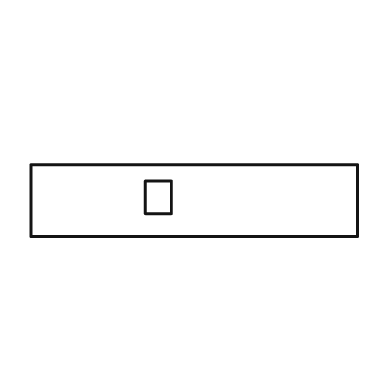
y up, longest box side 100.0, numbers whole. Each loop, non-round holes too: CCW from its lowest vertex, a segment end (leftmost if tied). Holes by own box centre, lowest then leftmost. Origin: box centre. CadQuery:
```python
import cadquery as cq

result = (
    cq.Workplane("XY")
    .moveTo(-50.0, -11.0)
    .lineTo(50.0, -11.0)
    .lineTo(50.0, 11.0)
    .lineTo(-50.0, 11.0)
    .close()
    .moveTo(-15.0, -4.0)
    .lineTo(-7.0, -4.0)
    .lineTo(-7.0, 6.0)
    .lineTo(-15.0, 6.0)
    .close()
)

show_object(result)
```